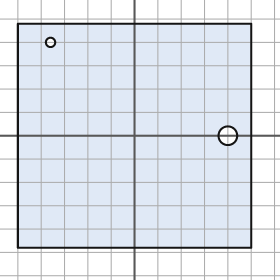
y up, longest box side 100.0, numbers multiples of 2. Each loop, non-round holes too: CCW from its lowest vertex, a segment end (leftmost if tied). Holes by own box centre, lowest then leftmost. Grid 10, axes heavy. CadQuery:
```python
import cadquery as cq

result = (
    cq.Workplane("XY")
    .moveTo(-50.0, -48.0)
    .lineTo(50.0, -48.0)
    .lineTo(50.0, 48.0)
    .lineTo(-50.0, 48.0)
    .close()
    .moveTo(40.0, 0.0)
    .circle(4.0)
    .moveTo(-36.0, 40.0)
    .circle(2.0)
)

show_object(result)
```